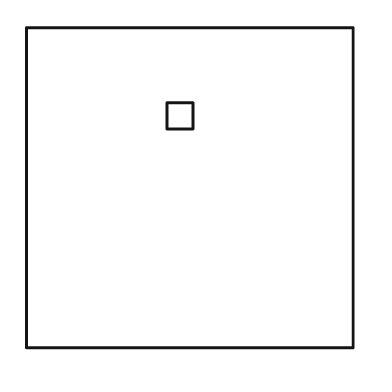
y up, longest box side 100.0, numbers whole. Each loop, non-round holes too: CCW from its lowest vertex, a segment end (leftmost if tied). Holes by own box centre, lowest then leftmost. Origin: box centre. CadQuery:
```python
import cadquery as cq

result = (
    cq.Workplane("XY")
    .moveTo(-50.0, -49.0)
    .lineTo(50.0, -49.0)
    .lineTo(50.0, 49.0)
    .lineTo(-50.0, 49.0)
    .close()
    .moveTo(-7.0, 18.0)
    .lineTo(1.0, 18.0)
    .lineTo(1.0, 26.0)
    .lineTo(-7.0, 26.0)
    .close()
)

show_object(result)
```